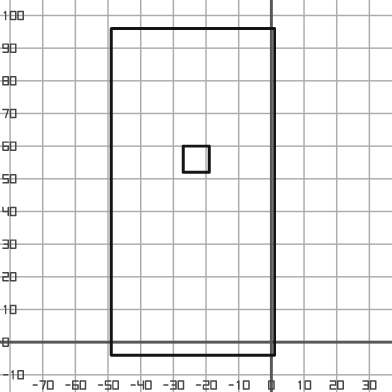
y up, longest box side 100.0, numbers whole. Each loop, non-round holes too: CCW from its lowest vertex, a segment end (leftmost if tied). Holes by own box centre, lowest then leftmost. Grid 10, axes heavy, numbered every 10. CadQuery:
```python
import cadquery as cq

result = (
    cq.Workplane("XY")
    .moveTo(-49.0, -4.0)
    .lineTo(1.0, -4.0)
    .lineTo(1.0, 96.0)
    .lineTo(-49.0, 96.0)
    .close()
    .moveTo(-27.0, 52.0)
    .lineTo(-19.0, 52.0)
    .lineTo(-19.0, 60.0)
    .lineTo(-27.0, 60.0)
    .close()
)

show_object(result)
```